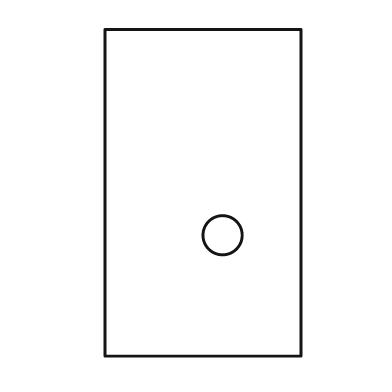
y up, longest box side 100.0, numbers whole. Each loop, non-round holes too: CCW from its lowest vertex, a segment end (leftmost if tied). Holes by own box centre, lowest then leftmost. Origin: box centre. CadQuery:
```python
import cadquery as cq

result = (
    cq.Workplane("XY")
    .moveTo(-30.0, -50.0)
    .lineTo(30.0, -50.0)
    .lineTo(30.0, 50.0)
    .lineTo(-30.0, 50.0)
    .close()
    .moveTo(6.0, -13.0)
    .circle(6.0)
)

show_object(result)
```